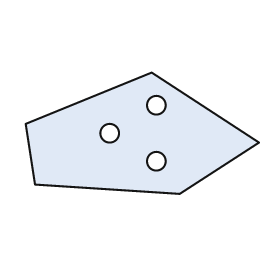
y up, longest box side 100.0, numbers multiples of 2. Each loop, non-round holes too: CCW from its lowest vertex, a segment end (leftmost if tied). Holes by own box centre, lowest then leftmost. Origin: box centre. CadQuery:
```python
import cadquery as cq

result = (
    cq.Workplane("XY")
    .moveTo(16.0, -26.0)
    .lineTo(50.0, -4.0)
    .lineTo(4.0, 26.0)
    .lineTo(-50.0, 4.0)
    .lineTo(-46.0, -22.0)
    .close()
    .moveTo(6.0, -12.0)
    .circle(4.0)
    .moveTo(-14.0, 0.0)
    .circle(4.0)
    .moveTo(6.0, 12.0)
    .circle(4.0)
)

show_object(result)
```